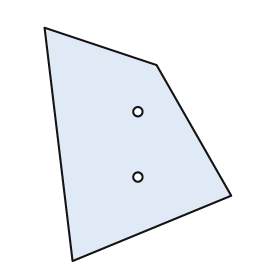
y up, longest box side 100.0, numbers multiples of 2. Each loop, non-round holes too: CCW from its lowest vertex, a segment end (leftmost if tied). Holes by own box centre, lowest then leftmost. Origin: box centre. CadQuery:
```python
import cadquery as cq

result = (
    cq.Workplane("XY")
    .moveTo(-28.0, -50.0)
    .lineTo(40.0, -22.0)
    .lineTo(8.0, 34.0)
    .lineTo(-40.0, 50.0)
    .close()
    .moveTo(0.0, -14.0)
    .circle(2.0)
    .moveTo(0.0, 14.0)
    .circle(2.0)
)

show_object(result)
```